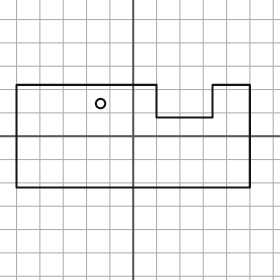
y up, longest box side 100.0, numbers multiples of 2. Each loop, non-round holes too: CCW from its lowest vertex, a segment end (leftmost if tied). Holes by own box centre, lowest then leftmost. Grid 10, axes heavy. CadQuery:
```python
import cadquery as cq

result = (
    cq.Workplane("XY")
    .moveTo(-50.0, -22.0)
    .lineTo(50.0, -22.0)
    .lineTo(50.0, 22.0)
    .lineTo(34.0, 22.0)
    .lineTo(34.0, 8.0)
    .lineTo(10.0, 8.0)
    .lineTo(10.0, 22.0)
    .lineTo(-50.0, 22.0)
    .close()
    .moveTo(-14.0, 14.0)
    .circle(2.0)
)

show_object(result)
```